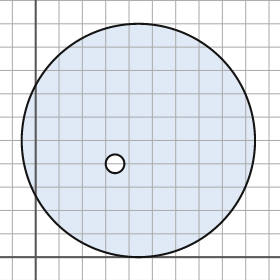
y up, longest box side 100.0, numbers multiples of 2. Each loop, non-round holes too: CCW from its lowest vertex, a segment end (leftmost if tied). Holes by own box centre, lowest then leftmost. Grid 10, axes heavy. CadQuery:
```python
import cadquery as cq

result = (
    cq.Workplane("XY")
    .moveTo(44.0, 50.0)
    .circle(50.0)
    .moveTo(34.0, 40.0)
    .circle(4.0)
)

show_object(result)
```